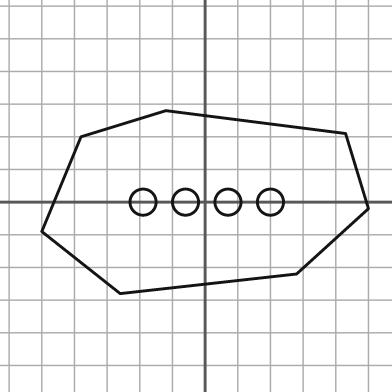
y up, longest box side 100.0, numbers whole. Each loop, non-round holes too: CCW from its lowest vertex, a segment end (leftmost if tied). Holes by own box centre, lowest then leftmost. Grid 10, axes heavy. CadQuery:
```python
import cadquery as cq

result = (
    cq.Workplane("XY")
    .moveTo(-26.0, -28.0)
    .lineTo(28.0, -22.0)
    .lineTo(50.0, -2.0)
    .lineTo(43.0, 21.0)
    .lineTo(-12.0, 28.0)
    .lineTo(-38.0, 20.0)
    .lineTo(-50.0, -9.0)
    .close()
    .moveTo(-19.0, 0.0)
    .circle(4.0)
    .moveTo(-6.0, 0.0)
    .circle(4.0)
    .moveTo(7.0, 0.0)
    .circle(4.0)
    .moveTo(20.0, 0.0)
    .circle(4.0)
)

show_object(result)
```